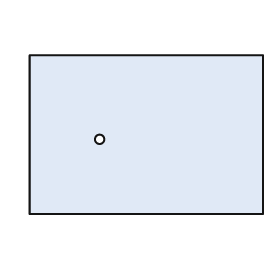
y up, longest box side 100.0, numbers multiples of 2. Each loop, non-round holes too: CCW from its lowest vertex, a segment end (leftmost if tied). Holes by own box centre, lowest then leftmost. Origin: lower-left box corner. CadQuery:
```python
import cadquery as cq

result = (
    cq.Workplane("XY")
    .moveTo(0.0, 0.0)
    .lineTo(100.0, 0.0)
    .lineTo(100.0, 68.0)
    .lineTo(0.0, 68.0)
    .close()
    .moveTo(30.0, 32.0)
    .circle(2.0)
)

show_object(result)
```